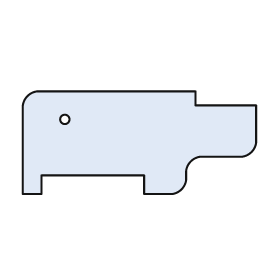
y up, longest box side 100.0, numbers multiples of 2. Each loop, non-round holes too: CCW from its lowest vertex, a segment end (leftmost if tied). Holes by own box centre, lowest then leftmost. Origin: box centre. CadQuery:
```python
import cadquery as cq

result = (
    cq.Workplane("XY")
    .moveTo(-50.0, -22.0)
    .lineTo(-42.0, -22.0)
    .lineTo(-42.0, -14.0)
    .lineTo(2.0, -14.0)
    .lineTo(2.0, -22.0)
    .lineTo(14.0, -22.0)
    .threePointArc((18.0, -20.0), (20.0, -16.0))
    .lineTo(20.0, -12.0)
    .threePointArc((22.0, -8.0), (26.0, -6.0))
    .lineTo(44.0, -6.0)
    .threePointArc((48.0, -4.0), (50.0, 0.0))
    .lineTo(50.0, 16.0)
    .lineTo(24.0, 16.0)
    .lineTo(24.0, 22.0)
    .lineTo(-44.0, 22.0)
    .threePointArc((-48.0, 20.0), (-50.0, 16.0))
    .close()
    .moveTo(-32.0, 10.0)
    .circle(2.0)
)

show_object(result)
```